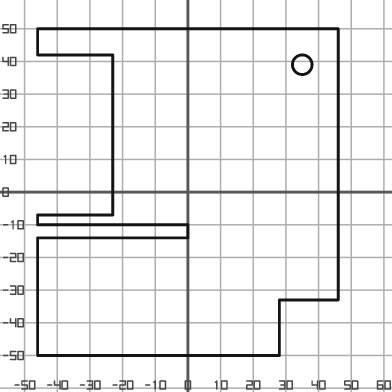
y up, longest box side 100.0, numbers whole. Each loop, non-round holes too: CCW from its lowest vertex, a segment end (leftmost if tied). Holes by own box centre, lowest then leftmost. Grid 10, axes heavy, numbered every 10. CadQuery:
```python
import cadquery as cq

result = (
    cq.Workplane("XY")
    .moveTo(-46.0, -50.0)
    .lineTo(28.0, -50.0)
    .lineTo(28.0, -33.0)
    .lineTo(46.0, -33.0)
    .lineTo(46.0, 50.0)
    .lineTo(-46.0, 50.0)
    .lineTo(-46.0, 42.0)
    .lineTo(-23.0, 42.0)
    .lineTo(-23.0, -7.0)
    .lineTo(-46.0, -7.0)
    .lineTo(-46.0, -10.0)
    .lineTo(0.0, -10.0)
    .lineTo(0.0, -14.0)
    .lineTo(-46.0, -14.0)
    .close()
    .moveTo(35.0, 39.0)
    .circle(3.0)
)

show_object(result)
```